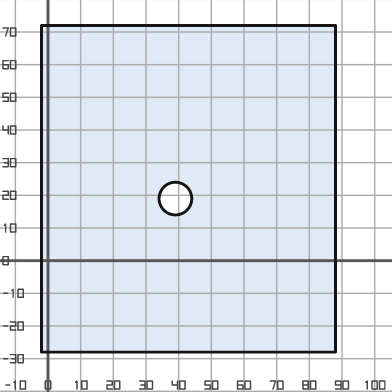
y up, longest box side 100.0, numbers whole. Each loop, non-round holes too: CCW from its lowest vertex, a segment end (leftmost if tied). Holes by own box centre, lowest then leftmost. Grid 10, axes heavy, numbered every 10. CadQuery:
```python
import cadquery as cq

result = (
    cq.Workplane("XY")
    .moveTo(-2.0, -28.0)
    .lineTo(88.0, -28.0)
    .lineTo(88.0, 72.0)
    .lineTo(-2.0, 72.0)
    .close()
    .moveTo(39.0, 19.0)
    .circle(5.0)
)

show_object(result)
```